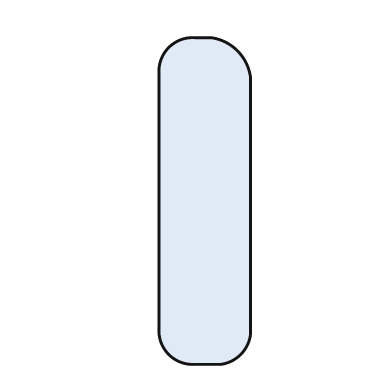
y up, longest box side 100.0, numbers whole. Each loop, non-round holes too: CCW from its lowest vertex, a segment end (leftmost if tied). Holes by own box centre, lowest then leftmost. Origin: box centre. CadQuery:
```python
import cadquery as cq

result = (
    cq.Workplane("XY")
    .moveTo(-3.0, -50.0)
    .lineTo(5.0, -50.0)
    .threePointArc((11.0, -47.0), (14.0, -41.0))
    .lineTo(14.0, 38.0)
    .threePointArc((10.0, 46.0), (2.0, 50.0))
    .lineTo(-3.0, 50.0)
    .threePointArc((-11.0, 47.0), (-14.0, 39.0))
    .lineTo(-14.0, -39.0)
    .threePointArc((-11.0, -47.0), (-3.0, -50.0))
    .close()
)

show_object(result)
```